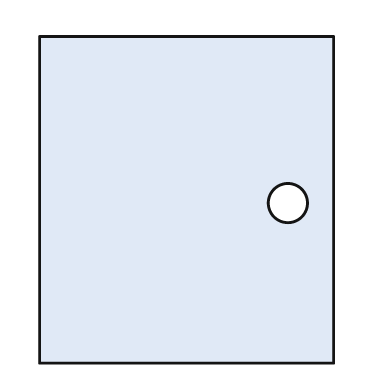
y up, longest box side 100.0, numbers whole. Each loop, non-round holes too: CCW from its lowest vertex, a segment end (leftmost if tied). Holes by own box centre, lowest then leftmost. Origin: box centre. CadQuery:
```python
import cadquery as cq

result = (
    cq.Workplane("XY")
    .moveTo(-45.0, -50.0)
    .lineTo(45.0, -50.0)
    .lineTo(45.0, 50.0)
    .lineTo(-45.0, 50.0)
    .close()
    .moveTo(31.0, -1.0)
    .circle(6.0)
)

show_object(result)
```